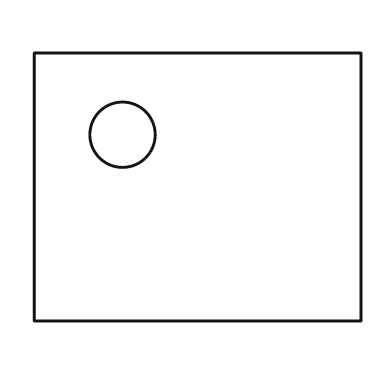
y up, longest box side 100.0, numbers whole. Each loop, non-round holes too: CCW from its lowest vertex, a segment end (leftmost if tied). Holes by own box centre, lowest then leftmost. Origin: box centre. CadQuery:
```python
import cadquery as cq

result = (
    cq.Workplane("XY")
    .moveTo(-50.0, -41.0)
    .lineTo(50.0, -41.0)
    .lineTo(50.0, 41.0)
    .lineTo(-50.0, 41.0)
    .close()
    .moveTo(-23.0, 16.0)
    .circle(10.0)
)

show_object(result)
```